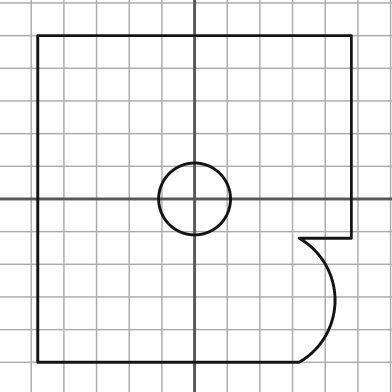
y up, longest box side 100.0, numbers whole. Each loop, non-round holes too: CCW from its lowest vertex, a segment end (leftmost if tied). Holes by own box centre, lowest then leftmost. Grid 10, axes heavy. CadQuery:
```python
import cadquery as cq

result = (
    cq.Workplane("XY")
    .moveTo(-48.0, -50.0)
    .lineTo(32.0, -50.0)
    .threePointArc((43.0, -31.0), (32.0, -12.0))
    .lineTo(48.0, -12.0)
    .lineTo(48.0, 50.0)
    .lineTo(-48.0, 50.0)
    .close()
    .moveTo(0.0, 0.0)
    .circle(11.0)
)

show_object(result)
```